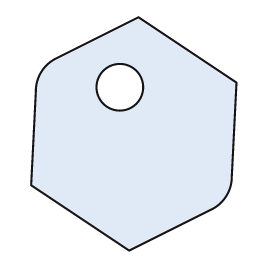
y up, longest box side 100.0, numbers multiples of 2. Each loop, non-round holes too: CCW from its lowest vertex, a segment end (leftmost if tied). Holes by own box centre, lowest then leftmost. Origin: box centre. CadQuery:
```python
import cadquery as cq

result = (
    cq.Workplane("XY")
    .moveTo(-2.0, -50.0)
    .lineTo(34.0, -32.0)
    .threePointArc((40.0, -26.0), (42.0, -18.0))
    .lineTo(44.0, 22.0)
    .lineTo(2.0, 50.0)
    .lineTo(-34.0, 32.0)
    .threePointArc((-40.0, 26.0), (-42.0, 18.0))
    .lineTo(-44.0, -22.0)
    .close()
    .moveTo(-6.0, 20.0)
    .circle(10.0)
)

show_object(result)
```